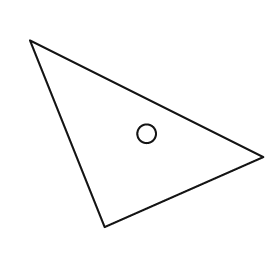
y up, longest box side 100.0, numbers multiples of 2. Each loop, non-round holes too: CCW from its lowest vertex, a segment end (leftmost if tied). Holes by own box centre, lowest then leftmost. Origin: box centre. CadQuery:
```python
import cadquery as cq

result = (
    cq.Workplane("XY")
    .moveTo(-18.0, -40.0)
    .lineTo(50.0, -10.0)
    .lineTo(-50.0, 40.0)
    .close()
    .moveTo(0.0, 0.0)
    .circle(4.0)
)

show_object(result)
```